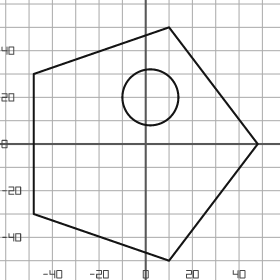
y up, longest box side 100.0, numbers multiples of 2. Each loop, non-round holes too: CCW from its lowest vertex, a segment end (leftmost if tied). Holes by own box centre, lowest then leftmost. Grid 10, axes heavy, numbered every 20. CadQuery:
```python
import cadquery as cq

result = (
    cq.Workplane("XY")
    .moveTo(10.0, -50.0)
    .lineTo(48.0, 0.0)
    .lineTo(10.0, 50.0)
    .lineTo(-48.0, 30.0)
    .lineTo(-48.0, -30.0)
    .close()
    .moveTo(2.0, 20.0)
    .circle(12.0)
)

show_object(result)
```